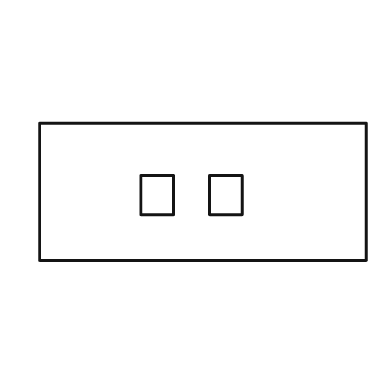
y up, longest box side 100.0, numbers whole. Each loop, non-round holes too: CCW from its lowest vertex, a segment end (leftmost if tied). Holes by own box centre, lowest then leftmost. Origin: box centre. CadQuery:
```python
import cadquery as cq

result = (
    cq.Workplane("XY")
    .moveTo(-50.0, -21.0)
    .lineTo(50.0, -21.0)
    .lineTo(50.0, 21.0)
    .lineTo(-50.0, 21.0)
    .close()
    .moveTo(-19.0, -7.0)
    .lineTo(-9.0, -7.0)
    .lineTo(-9.0, 5.0)
    .lineTo(-19.0, 5.0)
    .close()
    .moveTo(2.0, -7.0)
    .lineTo(12.0, -7.0)
    .lineTo(12.0, 5.0)
    .lineTo(2.0, 5.0)
    .close()
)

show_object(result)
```